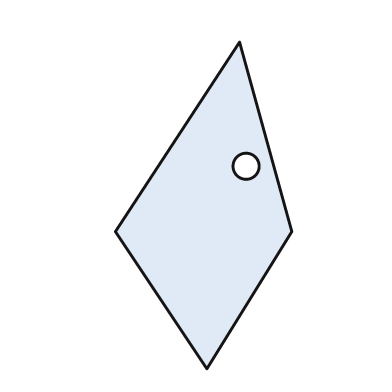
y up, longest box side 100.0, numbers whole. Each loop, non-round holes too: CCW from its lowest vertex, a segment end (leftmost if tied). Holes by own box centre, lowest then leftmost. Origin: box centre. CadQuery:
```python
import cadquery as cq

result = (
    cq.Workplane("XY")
    .moveTo(1.0, -50.0)
    .lineTo(27.0, -8.0)
    .lineTo(11.0, 50.0)
    .lineTo(-27.0, -8.0)
    .close()
    .moveTo(13.0, 12.0)
    .circle(4.0)
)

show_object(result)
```